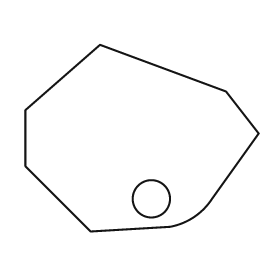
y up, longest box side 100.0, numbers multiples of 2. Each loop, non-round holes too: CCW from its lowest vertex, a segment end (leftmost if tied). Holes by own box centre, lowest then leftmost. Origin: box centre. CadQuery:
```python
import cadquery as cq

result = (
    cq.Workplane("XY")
    .moveTo(-22.0, -40.0)
    .lineTo(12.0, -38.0)
    .threePointArc((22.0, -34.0), (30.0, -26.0))
    .lineTo(50.0, 2.0)
    .lineTo(36.0, 20.0)
    .lineTo(-18.0, 40.0)
    .lineTo(-50.0, 12.0)
    .lineTo(-50.0, -12.0)
    .close()
    .moveTo(4.0, -26.0)
    .circle(8.0)
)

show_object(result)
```